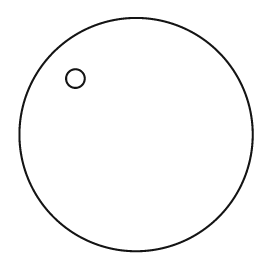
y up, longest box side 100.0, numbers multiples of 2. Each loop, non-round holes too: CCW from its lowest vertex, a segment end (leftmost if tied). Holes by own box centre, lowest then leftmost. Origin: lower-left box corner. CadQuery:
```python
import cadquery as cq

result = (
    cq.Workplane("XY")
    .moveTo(50.0, 50.0)
    .circle(50.0)
    .moveTo(24.0, 74.0)
    .circle(4.0)
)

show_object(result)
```